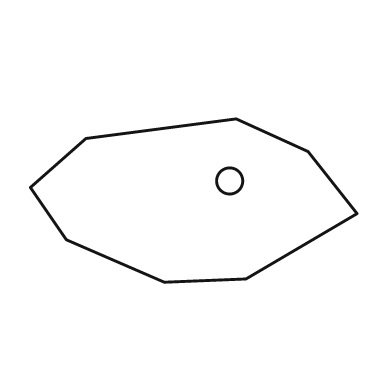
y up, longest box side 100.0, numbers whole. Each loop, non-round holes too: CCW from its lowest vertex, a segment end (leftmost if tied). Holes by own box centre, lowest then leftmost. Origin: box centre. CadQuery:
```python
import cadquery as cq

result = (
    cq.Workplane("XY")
    .moveTo(-9.0, -25.0)
    .lineTo(16.0, -24.0)
    .lineTo(50.0, -4.0)
    .lineTo(35.0, 15.0)
    .lineTo(13.0, 25.0)
    .lineTo(-33.0, 19.0)
    .lineTo(-50.0, 4.0)
    .lineTo(-39.0, -12.0)
    .close()
    .moveTo(11.0, 6.0)
    .circle(4.0)
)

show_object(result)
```